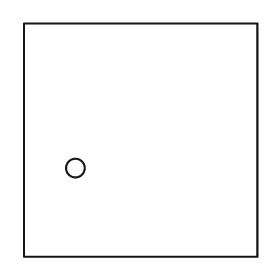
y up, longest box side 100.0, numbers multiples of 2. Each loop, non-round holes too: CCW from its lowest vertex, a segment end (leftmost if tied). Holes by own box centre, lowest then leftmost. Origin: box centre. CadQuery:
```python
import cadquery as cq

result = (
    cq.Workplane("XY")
    .moveTo(-50.0, -50.0)
    .lineTo(50.0, -50.0)
    .lineTo(50.0, 50.0)
    .lineTo(-50.0, 50.0)
    .close()
    .moveTo(-28.0, -12.0)
    .circle(4.0)
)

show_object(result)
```